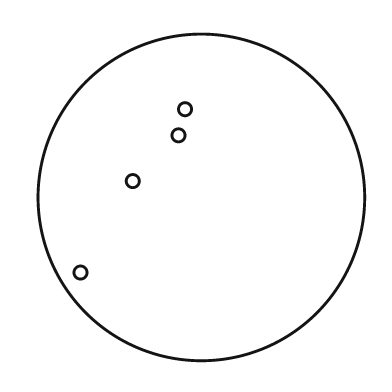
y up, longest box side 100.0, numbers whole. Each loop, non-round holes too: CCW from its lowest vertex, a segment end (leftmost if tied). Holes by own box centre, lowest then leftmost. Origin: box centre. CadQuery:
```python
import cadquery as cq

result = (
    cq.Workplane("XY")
    .moveTo(0.0, 0.0)
    .circle(50.0)
    .moveTo(-37.0, -23.0)
    .circle(2.0)
    .moveTo(-21.0, 5.0)
    .circle(2.0)
    .moveTo(-7.0, 19.0)
    .circle(2.0)
    .moveTo(-5.0, 27.0)
    .circle(2.0)
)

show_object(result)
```